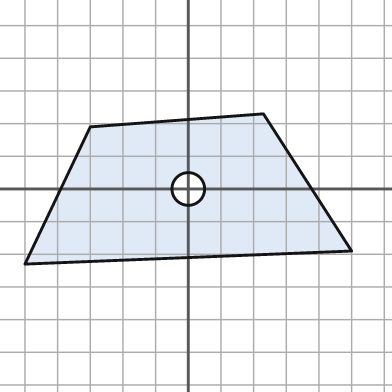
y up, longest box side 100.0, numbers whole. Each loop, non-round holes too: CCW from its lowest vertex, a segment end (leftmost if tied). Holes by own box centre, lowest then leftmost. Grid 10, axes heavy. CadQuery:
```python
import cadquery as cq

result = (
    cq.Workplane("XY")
    .moveTo(-50.0, -23.0)
    .lineTo(50.0, -19.0)
    .lineTo(23.0, 23.0)
    .lineTo(-30.0, 19.0)
    .close()
    .moveTo(0.0, 0.0)
    .circle(5.0)
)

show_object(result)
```